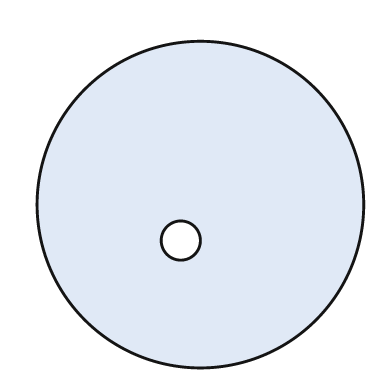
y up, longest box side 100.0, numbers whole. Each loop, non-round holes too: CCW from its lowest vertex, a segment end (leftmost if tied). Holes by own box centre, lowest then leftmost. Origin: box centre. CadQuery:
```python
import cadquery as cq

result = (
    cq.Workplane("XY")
    .moveTo(0.0, 0.0)
    .circle(50.0)
    .moveTo(-6.0, -11.0)
    .circle(6.0)
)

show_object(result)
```